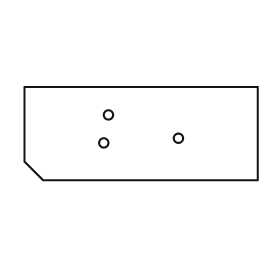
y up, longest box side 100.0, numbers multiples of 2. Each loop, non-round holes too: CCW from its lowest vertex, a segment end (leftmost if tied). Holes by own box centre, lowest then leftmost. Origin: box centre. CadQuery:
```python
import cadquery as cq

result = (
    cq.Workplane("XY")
    .moveTo(-42.0, -20.0)
    .lineTo(50.0, -20.0)
    .lineTo(50.0, 20.0)
    .lineTo(-50.0, 20.0)
    .lineTo(-50.0, -12.0)
    .close()
    .moveTo(-16.0, -4.0)
    .circle(2.0)
    .moveTo(16.0, -2.0)
    .circle(2.0)
    .moveTo(-14.0, 8.0)
    .circle(2.0)
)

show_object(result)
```